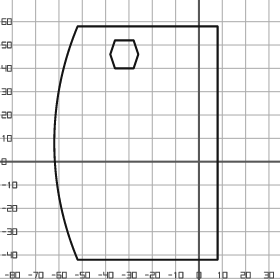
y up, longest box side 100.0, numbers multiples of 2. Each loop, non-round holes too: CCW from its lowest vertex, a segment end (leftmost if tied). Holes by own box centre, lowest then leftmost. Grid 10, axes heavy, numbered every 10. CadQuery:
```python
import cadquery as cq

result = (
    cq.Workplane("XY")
    .moveTo(-52.0, -42.0)
    .lineTo(8.0, -42.0)
    .lineTo(8.0, 58.0)
    .lineTo(-52.0, 58.0)
    .threePointArc((-62.0, 8.0), (-52.0, -42.0))
    .close()
    .moveTo(-36.0, 40.0)
    .lineTo(-28.0, 40.0)
    .lineTo(-26.0, 46.0)
    .lineTo(-28.0, 52.0)
    .lineTo(-36.0, 52.0)
    .lineTo(-38.0, 46.0)
    .close()
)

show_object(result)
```